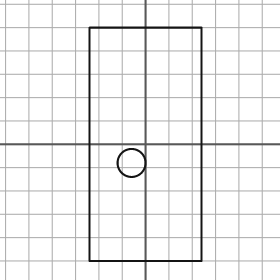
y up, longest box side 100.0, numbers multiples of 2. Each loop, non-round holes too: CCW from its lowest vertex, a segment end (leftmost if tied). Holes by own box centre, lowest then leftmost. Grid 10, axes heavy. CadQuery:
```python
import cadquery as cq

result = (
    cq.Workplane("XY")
    .moveTo(-24.0, -50.0)
    .lineTo(24.0, -50.0)
    .lineTo(24.0, 50.0)
    .lineTo(-24.0, 50.0)
    .close()
    .moveTo(-6.0, -8.0)
    .circle(6.0)
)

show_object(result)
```